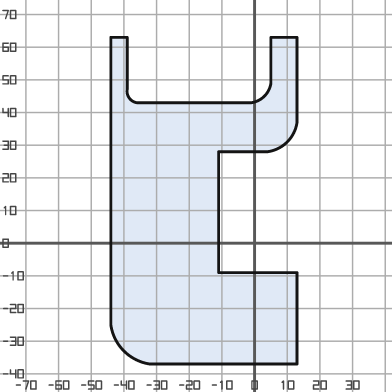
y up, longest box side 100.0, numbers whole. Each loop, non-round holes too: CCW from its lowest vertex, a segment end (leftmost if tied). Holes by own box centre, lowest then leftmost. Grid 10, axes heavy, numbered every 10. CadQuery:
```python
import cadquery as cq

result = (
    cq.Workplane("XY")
    .moveTo(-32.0, -37.0)
    .lineTo(13.0, -37.0)
    .lineTo(13.0, -9.0)
    .lineTo(-11.0, -9.0)
    .lineTo(-11.0, 28.0)
    .lineTo(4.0, 28.0)
    .threePointArc((10.0, 31.0), (13.0, 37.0))
    .lineTo(13.0, 63.0)
    .lineTo(5.0, 63.0)
    .lineTo(5.0, 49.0)
    .threePointArc((3.0, 45.0), (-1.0, 43.0))
    .lineTo(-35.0, 43.0)
    .threePointArc((-38.0, 44.0), (-39.0, 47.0))
    .lineTo(-39.0, 63.0)
    .lineTo(-44.0, 63.0)
    .lineTo(-44.0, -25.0)
    .threePointArc((-40.0, -33.0), (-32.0, -37.0))
    .close()
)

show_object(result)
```